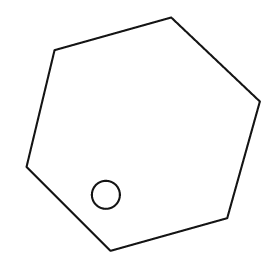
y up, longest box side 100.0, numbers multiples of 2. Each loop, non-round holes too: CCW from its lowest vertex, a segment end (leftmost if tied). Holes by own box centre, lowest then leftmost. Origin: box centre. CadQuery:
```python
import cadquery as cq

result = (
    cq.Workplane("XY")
    .moveTo(-14.0, -50.0)
    .lineTo(36.0, -36.0)
    .lineTo(50.0, 14.0)
    .lineTo(12.0, 50.0)
    .lineTo(-38.0, 36.0)
    .lineTo(-50.0, -14.0)
    .close()
    .moveTo(-16.0, -26.0)
    .circle(6.0)
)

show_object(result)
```